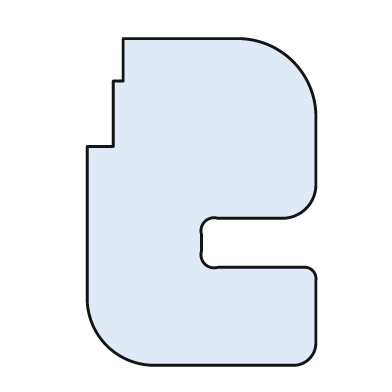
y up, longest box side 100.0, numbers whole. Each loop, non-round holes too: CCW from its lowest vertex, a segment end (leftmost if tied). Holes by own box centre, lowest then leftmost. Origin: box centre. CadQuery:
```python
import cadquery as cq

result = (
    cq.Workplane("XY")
    .moveTo(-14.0, -50.0)
    .lineTo(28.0, -50.0)
    .threePointArc((33.0, -48.0), (35.0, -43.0))
    .lineTo(35.0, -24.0)
    .threePointArc((34.0, -21.0), (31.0, -20.0))
    .lineTo(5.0, -20.0)
    .threePointArc((1.0, -19.0), (0.0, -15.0))
    .lineTo(0.0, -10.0)
    .threePointArc((1.0, -6.0), (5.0, -5.0))
    .lineTo(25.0, -5.0)
    .threePointArc((32.0, -2.0), (35.0, 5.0))
    .lineTo(35.0, 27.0)
    .threePointArc((28.0, 43.0), (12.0, 50.0))
    .lineTo(-24.0, 50.0)
    .lineTo(-24.0, 37.0)
    .lineTo(-27.0, 37.0)
    .lineTo(-27.0, 17.0)
    .lineTo(-35.0, 17.0)
    .lineTo(-35.0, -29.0)
    .threePointArc((-29.0, -44.0), (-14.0, -50.0))
    .close()
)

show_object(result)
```